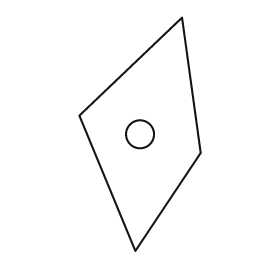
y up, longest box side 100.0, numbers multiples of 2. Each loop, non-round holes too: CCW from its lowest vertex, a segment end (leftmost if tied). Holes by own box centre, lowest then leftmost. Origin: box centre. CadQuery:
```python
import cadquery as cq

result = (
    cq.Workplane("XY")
    .moveTo(-2.0, -50.0)
    .lineTo(26.0, -8.0)
    .lineTo(18.0, 50.0)
    .lineTo(-26.0, 8.0)
    .close()
    .moveTo(0.0, 0.0)
    .circle(6.0)
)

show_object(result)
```